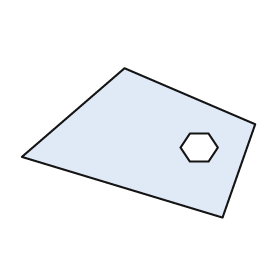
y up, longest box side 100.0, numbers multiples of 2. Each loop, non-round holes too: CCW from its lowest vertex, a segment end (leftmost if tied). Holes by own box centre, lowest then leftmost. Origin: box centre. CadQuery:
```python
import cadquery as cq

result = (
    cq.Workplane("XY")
    .moveTo(36.0, -32.0)
    .lineTo(50.0, 8.0)
    .lineTo(-6.0, 32.0)
    .lineTo(-50.0, -6.0)
    .close()
    .moveTo(22.0, -8.0)
    .lineTo(30.0, -8.0)
    .lineTo(34.0, -2.0)
    .lineTo(30.0, 4.0)
    .lineTo(22.0, 4.0)
    .lineTo(18.0, -2.0)
    .close()
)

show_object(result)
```